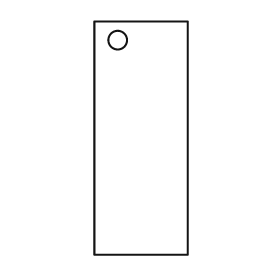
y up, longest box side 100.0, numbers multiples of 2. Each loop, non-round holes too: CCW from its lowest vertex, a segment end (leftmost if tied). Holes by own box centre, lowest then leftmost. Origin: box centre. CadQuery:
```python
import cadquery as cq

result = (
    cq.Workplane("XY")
    .moveTo(-20.0, -50.0)
    .lineTo(20.0, -50.0)
    .lineTo(20.0, 50.0)
    .lineTo(-20.0, 50.0)
    .close()
    .moveTo(-10.0, 42.0)
    .circle(4.0)
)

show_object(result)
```